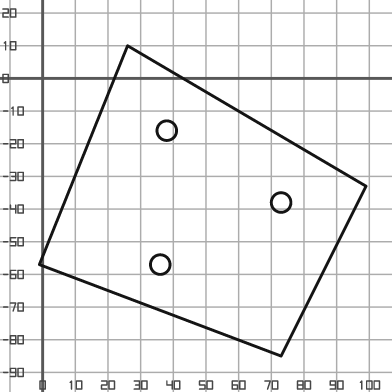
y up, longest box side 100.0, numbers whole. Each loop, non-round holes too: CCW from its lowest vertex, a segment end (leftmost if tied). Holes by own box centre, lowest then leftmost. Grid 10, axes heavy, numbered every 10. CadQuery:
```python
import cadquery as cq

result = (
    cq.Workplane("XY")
    .moveTo(73.0, -85.0)
    .lineTo(99.0, -33.0)
    .lineTo(26.0, 10.0)
    .lineTo(-1.0, -57.0)
    .close()
    .moveTo(36.0, -57.0)
    .circle(3.0)
    .moveTo(73.0, -38.0)
    .circle(3.0)
    .moveTo(38.0, -16.0)
    .circle(3.0)
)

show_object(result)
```